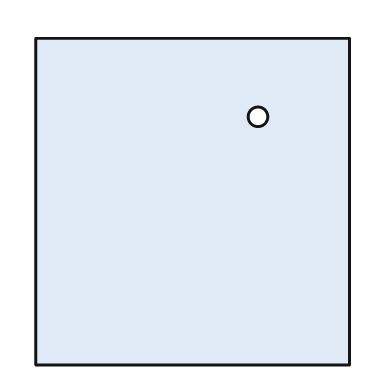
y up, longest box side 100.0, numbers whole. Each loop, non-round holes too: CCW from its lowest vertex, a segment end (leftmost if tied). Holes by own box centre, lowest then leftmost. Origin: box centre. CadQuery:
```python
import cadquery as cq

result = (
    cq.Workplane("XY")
    .moveTo(-48.0, -50.0)
    .lineTo(48.0, -50.0)
    .lineTo(48.0, 50.0)
    .lineTo(-48.0, 50.0)
    .close()
    .moveTo(20.0, 26.0)
    .circle(3.0)
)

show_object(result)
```